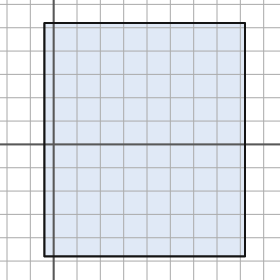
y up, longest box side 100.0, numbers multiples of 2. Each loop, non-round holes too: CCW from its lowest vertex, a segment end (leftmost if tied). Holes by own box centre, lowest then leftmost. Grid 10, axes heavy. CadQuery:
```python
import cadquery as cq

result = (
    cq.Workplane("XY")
    .moveTo(-4.0, -48.0)
    .lineTo(82.0, -48.0)
    .lineTo(82.0, 52.0)
    .lineTo(-4.0, 52.0)
    .close()
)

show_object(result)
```